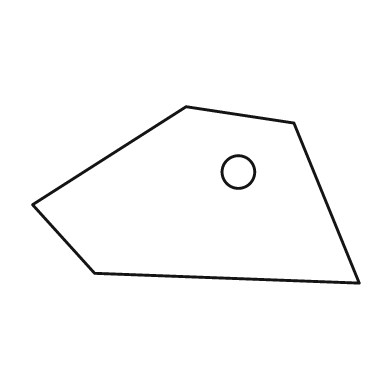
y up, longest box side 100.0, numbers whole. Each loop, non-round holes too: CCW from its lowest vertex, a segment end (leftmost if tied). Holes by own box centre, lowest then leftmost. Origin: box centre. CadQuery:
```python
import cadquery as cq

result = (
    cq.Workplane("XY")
    .moveTo(50.0, -27.0)
    .lineTo(30.0, 22.0)
    .lineTo(-3.0, 27.0)
    .lineTo(-50.0, -3.0)
    .lineTo(-31.0, -24.0)
    .close()
    .moveTo(13.0, 7.0)
    .circle(5.0)
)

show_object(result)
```